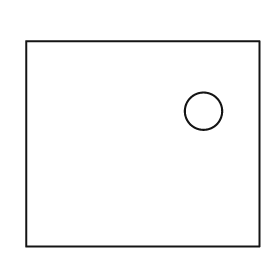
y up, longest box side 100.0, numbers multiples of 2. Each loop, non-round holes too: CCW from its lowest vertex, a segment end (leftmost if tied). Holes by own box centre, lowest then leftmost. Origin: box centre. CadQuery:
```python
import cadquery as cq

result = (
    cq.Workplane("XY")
    .moveTo(-50.0, -44.0)
    .lineTo(50.0, -44.0)
    .lineTo(50.0, 44.0)
    .lineTo(-50.0, 44.0)
    .close()
    .moveTo(26.0, 14.0)
    .circle(8.0)
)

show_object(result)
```